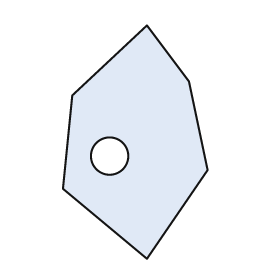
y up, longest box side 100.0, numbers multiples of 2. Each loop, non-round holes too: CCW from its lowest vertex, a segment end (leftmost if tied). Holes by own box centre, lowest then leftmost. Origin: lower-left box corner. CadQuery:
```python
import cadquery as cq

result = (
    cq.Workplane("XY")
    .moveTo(36.0, 0.0)
    .lineTo(62.0, 38.0)
    .lineTo(54.0, 76.0)
    .lineTo(36.0, 100.0)
    .lineTo(4.0, 70.0)
    .lineTo(0.0, 30.0)
    .close()
    .moveTo(20.0, 44.0)
    .circle(8.0)
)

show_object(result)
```